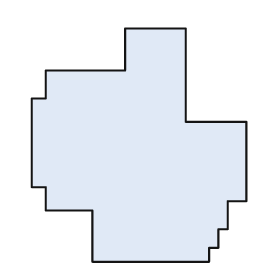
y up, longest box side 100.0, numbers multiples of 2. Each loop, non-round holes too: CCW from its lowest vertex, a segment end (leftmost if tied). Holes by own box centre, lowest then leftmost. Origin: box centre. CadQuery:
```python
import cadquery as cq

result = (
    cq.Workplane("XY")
    .moveTo(-20.0, -50.0)
    .lineTo(30.0, -50.0)
    .lineTo(30.0, -44.0)
    .lineTo(34.0, -44.0)
    .lineTo(34.0, -36.0)
    .lineTo(38.0, -36.0)
    .lineTo(38.0, -24.0)
    .lineTo(46.0, -24.0)
    .lineTo(46.0, 10.0)
    .lineTo(20.0, 10.0)
    .lineTo(20.0, 50.0)
    .lineTo(-6.0, 50.0)
    .lineTo(-6.0, 32.0)
    .lineTo(-40.0, 32.0)
    .lineTo(-40.0, 20.0)
    .lineTo(-46.0, 20.0)
    .lineTo(-46.0, -18.0)
    .lineTo(-40.0, -18.0)
    .lineTo(-40.0, -28.0)
    .lineTo(-20.0, -28.0)
    .close()
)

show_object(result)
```